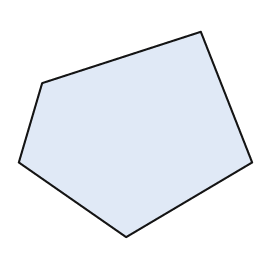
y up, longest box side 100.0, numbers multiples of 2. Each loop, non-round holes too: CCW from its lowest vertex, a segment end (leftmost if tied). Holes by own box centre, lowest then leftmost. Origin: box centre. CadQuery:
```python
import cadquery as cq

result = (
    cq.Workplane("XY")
    .moveTo(-4.0, -44.0)
    .lineTo(50.0, -12.0)
    .lineTo(28.0, 44.0)
    .lineTo(-40.0, 22.0)
    .lineTo(-50.0, -12.0)
    .close()
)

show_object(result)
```